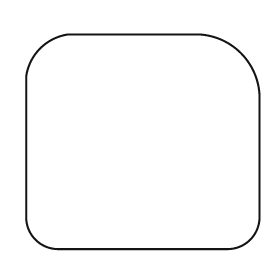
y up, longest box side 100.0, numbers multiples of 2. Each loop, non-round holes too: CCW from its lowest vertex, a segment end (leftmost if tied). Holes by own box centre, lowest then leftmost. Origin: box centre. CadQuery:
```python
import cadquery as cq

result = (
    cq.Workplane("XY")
    .moveTo(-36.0, -46.0)
    .lineTo(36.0, -46.0)
    .threePointArc((46.0, -42.0), (50.0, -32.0))
    .lineTo(50.0, 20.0)
    .threePointArc((42.0, 38.0), (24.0, 46.0))
    .lineTo(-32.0, 46.0)
    .threePointArc((-44.0, 40.0), (-50.0, 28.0))
    .lineTo(-50.0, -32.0)
    .threePointArc((-46.0, -42.0), (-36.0, -46.0))
    .close()
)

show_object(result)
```